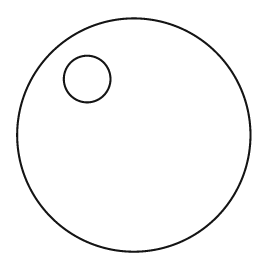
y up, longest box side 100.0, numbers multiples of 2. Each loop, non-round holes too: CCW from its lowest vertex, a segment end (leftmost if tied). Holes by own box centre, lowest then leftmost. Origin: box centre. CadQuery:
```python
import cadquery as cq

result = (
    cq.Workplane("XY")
    .moveTo(0.0, 0.0)
    .circle(50.0)
    .moveTo(-20.0, 24.0)
    .circle(10.0)
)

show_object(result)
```